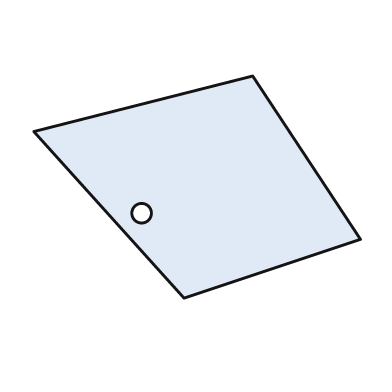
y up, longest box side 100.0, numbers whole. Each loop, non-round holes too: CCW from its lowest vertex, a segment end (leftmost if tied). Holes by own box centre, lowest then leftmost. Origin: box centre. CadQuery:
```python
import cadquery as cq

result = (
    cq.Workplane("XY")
    .moveTo(-4.0, -34.0)
    .lineTo(50.0, -16.0)
    .lineTo(17.0, 34.0)
    .lineTo(-50.0, 17.0)
    .close()
    .moveTo(-17.0, -8.0)
    .circle(3.0)
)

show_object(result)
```